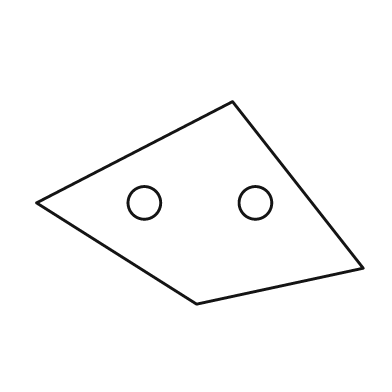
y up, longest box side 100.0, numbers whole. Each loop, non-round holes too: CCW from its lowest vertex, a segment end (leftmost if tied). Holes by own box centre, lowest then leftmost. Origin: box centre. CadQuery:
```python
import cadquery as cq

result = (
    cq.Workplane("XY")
    .moveTo(-1.0, -31.0)
    .lineTo(50.0, -20.0)
    .lineTo(10.0, 31.0)
    .lineTo(-50.0, 0.0)
    .close()
    .moveTo(-17.0, 0.0)
    .circle(5.0)
    .moveTo(17.0, 0.0)
    .circle(5.0)
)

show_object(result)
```